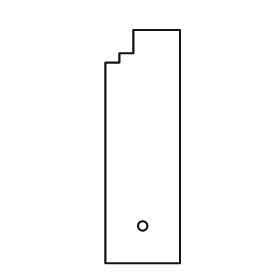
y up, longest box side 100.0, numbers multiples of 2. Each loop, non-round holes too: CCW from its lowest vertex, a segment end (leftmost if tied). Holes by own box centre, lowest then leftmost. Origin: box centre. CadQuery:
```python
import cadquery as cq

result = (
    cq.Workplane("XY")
    .moveTo(-16.0, -50.0)
    .lineTo(16.0, -50.0)
    .lineTo(16.0, 50.0)
    .lineTo(-4.0, 50.0)
    .lineTo(-4.0, 40.0)
    .lineTo(-10.0, 40.0)
    .lineTo(-10.0, 36.0)
    .lineTo(-16.0, 36.0)
    .close()
    .moveTo(0.0, -34.0)
    .circle(2.0)
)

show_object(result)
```